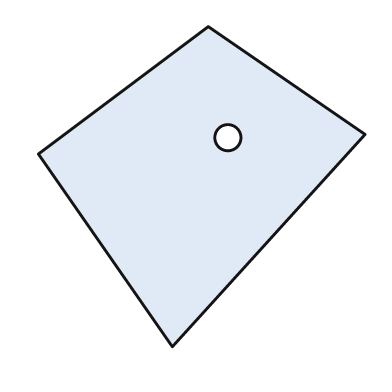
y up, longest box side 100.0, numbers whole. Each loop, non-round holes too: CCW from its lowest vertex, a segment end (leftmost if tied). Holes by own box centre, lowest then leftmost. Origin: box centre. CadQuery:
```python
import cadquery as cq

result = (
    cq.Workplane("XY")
    .moveTo(-9.0, -49.0)
    .lineTo(50.0, 16.0)
    .lineTo(2.0, 49.0)
    .lineTo(-50.0, 10.0)
    .close()
    .moveTo(8.0, 15.0)
    .circle(4.0)
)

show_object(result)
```